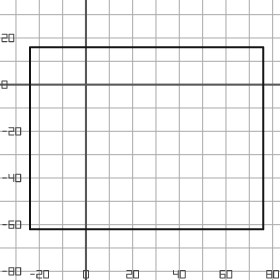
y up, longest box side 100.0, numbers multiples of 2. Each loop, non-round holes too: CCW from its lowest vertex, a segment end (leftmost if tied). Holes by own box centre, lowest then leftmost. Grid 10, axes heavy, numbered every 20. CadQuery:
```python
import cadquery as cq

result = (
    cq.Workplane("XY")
    .moveTo(-24.0, -62.0)
    .lineTo(76.0, -62.0)
    .lineTo(76.0, 16.0)
    .lineTo(-24.0, 16.0)
    .close()
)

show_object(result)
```